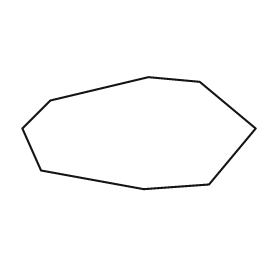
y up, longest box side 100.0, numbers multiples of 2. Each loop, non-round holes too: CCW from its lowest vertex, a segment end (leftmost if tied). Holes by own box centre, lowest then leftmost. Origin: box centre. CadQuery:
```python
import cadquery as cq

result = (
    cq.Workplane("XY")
    .moveTo(2.0, -24.0)
    .lineTo(30.0, -22.0)
    .lineTo(50.0, 2.0)
    .lineTo(26.0, 22.0)
    .lineTo(4.0, 24.0)
    .lineTo(-38.0, 14.0)
    .lineTo(-50.0, 2.0)
    .lineTo(-42.0, -16.0)
    .close()
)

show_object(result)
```